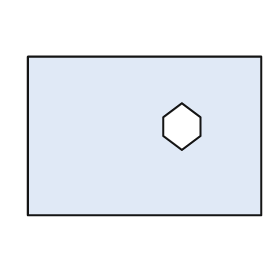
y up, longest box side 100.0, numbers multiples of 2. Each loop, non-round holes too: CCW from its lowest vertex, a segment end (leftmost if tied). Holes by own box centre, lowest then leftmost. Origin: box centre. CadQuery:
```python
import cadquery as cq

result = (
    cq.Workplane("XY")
    .moveTo(-50.0, -34.0)
    .lineTo(50.0, -34.0)
    .lineTo(50.0, 34.0)
    .lineTo(-50.0, 34.0)
    .close()
    .moveTo(16.0, -6.0)
    .lineTo(24.0, 0.0)
    .lineTo(24.0, 8.0)
    .lineTo(16.0, 14.0)
    .lineTo(8.0, 8.0)
    .lineTo(8.0, 0.0)
    .close()
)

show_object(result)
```